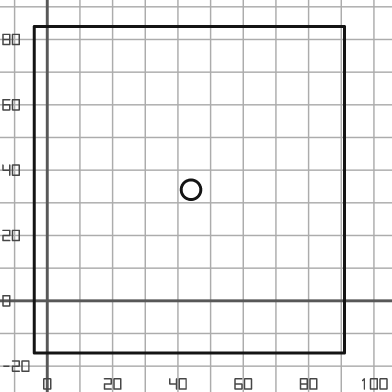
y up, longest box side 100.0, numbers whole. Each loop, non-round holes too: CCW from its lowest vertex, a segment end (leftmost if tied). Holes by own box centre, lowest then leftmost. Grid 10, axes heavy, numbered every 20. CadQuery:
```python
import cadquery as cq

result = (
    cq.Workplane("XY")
    .moveTo(-4.0, -16.0)
    .lineTo(91.0, -16.0)
    .lineTo(91.0, 84.0)
    .lineTo(-4.0, 84.0)
    .close()
    .moveTo(44.0, 34.0)
    .circle(3.0)
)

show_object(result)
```